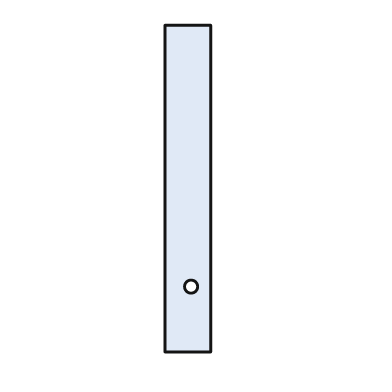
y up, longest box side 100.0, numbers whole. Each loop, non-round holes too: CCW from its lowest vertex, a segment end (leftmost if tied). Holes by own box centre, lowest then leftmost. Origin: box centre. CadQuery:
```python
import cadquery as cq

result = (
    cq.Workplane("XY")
    .moveTo(-7.0, -50.0)
    .lineTo(7.0, -50.0)
    .lineTo(7.0, 50.0)
    .lineTo(-7.0, 50.0)
    .close()
    .moveTo(1.0, -30.0)
    .circle(2.0)
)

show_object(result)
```